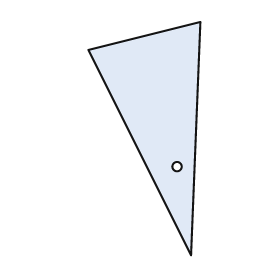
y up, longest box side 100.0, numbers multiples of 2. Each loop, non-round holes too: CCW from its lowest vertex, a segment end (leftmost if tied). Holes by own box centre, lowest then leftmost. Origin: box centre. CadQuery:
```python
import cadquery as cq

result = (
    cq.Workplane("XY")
    .moveTo(20.0, -50.0)
    .lineTo(24.0, 50.0)
    .lineTo(-24.0, 38.0)
    .close()
    .moveTo(14.0, -12.0)
    .circle(2.0)
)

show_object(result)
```